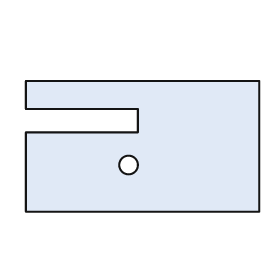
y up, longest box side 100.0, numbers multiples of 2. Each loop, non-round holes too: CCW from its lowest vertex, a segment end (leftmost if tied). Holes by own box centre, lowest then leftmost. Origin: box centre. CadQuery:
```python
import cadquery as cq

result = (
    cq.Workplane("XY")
    .moveTo(-50.0, -28.0)
    .lineTo(50.0, -28.0)
    .lineTo(50.0, 28.0)
    .lineTo(-50.0, 28.0)
    .lineTo(-50.0, 16.0)
    .lineTo(-2.0, 16.0)
    .lineTo(-2.0, 6.0)
    .lineTo(-50.0, 6.0)
    .close()
    .moveTo(-6.0, -8.0)
    .circle(4.0)
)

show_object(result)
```